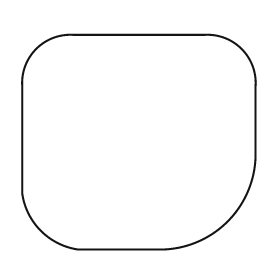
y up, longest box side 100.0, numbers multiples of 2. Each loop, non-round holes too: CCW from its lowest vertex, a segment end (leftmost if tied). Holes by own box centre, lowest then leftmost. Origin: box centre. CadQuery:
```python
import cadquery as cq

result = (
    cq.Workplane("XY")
    .moveTo(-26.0, -46.0)
    .lineTo(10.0, -46.0)
    .threePointArc((38.0, -34.0), (50.0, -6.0))
    .lineTo(50.0, 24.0)
    .threePointArc((44.0, 40.0), (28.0, 46.0))
    .lineTo(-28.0, 46.0)
    .threePointArc((-44.0, 40.0), (-50.0, 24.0))
    .lineTo(-50.0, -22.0)
    .threePointArc((-42.0, -38.0), (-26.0, -46.0))
    .close()
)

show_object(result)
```